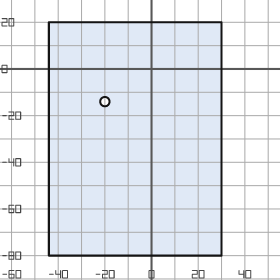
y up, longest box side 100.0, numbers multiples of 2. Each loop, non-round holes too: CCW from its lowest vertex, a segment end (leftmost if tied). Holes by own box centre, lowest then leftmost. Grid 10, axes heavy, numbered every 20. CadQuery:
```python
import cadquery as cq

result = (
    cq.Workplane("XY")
    .moveTo(-44.0, -80.0)
    .lineTo(30.0, -80.0)
    .lineTo(30.0, 20.0)
    .lineTo(-44.0, 20.0)
    .close()
    .moveTo(-20.0, -14.0)
    .circle(2.0)
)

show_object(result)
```